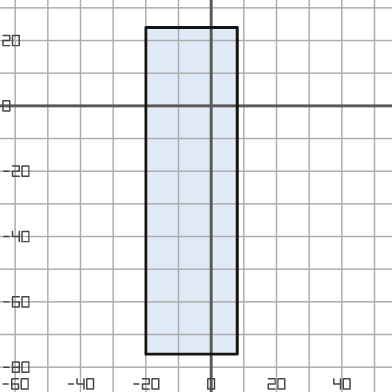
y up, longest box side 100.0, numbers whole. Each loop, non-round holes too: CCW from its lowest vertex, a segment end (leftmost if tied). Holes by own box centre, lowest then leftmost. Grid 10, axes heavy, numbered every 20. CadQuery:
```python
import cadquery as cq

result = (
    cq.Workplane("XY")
    .moveTo(-20.0, -76.0)
    .lineTo(8.0, -76.0)
    .lineTo(8.0, 24.0)
    .lineTo(-20.0, 24.0)
    .close()
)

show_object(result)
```